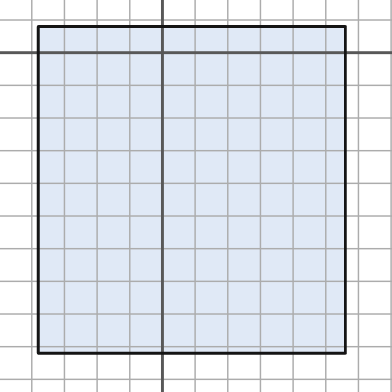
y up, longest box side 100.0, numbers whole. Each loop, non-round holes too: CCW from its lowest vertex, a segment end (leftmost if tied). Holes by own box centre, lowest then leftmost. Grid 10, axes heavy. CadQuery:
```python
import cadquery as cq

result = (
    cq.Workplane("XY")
    .moveTo(-38.0, -92.0)
    .lineTo(56.0, -92.0)
    .lineTo(56.0, 8.0)
    .lineTo(-38.0, 8.0)
    .close()
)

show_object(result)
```